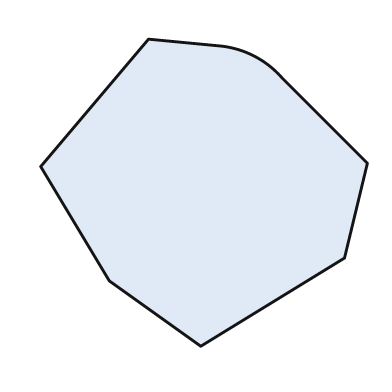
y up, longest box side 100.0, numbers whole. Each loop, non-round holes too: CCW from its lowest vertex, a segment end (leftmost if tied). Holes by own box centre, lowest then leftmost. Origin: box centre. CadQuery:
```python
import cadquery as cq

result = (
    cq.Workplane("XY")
    .moveTo(-1.0, -47.0)
    .lineTo(43.0, -20.0)
    .lineTo(50.0, 9.0)
    .lineTo(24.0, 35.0)
    .threePointArc((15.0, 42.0), (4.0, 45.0))
    .lineTo(-17.0, 47.0)
    .lineTo(-50.0, 8.0)
    .lineTo(-29.0, -27.0)
    .close()
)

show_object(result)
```